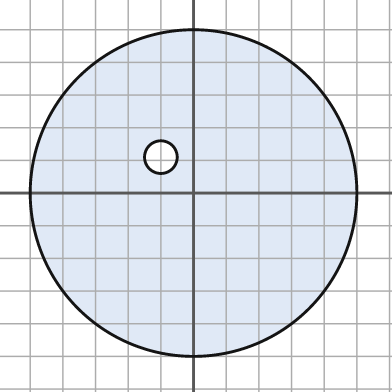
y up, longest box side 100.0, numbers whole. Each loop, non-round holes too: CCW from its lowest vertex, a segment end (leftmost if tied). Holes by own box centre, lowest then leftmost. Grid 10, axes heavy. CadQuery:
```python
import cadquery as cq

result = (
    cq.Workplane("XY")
    .moveTo(0.0, 0.0)
    .circle(50.0)
    .moveTo(-10.0, 11.0)
    .circle(5.0)
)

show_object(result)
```